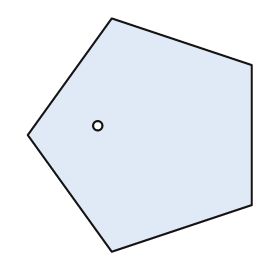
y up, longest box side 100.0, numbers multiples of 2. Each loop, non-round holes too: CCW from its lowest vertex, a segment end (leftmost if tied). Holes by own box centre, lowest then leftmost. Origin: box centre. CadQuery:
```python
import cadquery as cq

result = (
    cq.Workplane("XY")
    .moveTo(-12.0, -50.0)
    .lineTo(48.0, -30.0)
    .lineTo(48.0, 30.0)
    .lineTo(-12.0, 50.0)
    .lineTo(-48.0, 0.0)
    .close()
    .moveTo(-18.0, 4.0)
    .circle(2.0)
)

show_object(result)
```